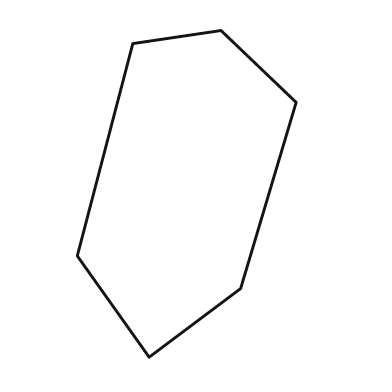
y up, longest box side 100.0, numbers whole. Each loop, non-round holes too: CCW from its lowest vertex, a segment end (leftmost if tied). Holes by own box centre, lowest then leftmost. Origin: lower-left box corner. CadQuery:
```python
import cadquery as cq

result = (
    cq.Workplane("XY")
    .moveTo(22.0, 0.0)
    .lineTo(50.0, 21.0)
    .lineTo(67.0, 78.0)
    .lineTo(44.0, 100.0)
    .lineTo(17.0, 96.0)
    .lineTo(0.0, 31.0)
    .close()
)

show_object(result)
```